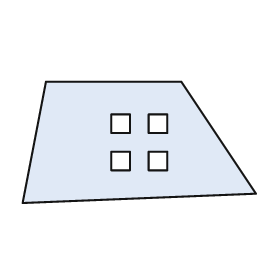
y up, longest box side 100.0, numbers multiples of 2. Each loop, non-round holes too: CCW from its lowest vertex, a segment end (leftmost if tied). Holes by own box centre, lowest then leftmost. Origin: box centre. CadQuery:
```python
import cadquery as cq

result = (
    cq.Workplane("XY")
    .moveTo(-50.0, -26.0)
    .lineTo(50.0, -22.0)
    .lineTo(18.0, 26.0)
    .lineTo(-40.0, 26.0)
    .close()
    .moveTo(-12.0, -12.0)
    .lineTo(-4.0, -12.0)
    .lineTo(-4.0, -4.0)
    .lineTo(-12.0, -4.0)
    .close()
    .moveTo(4.0, -12.0)
    .lineTo(12.0, -12.0)
    .lineTo(12.0, -4.0)
    .lineTo(4.0, -4.0)
    .close()
    .moveTo(-12.0, 4.0)
    .lineTo(-4.0, 4.0)
    .lineTo(-4.0, 12.0)
    .lineTo(-12.0, 12.0)
    .close()
    .moveTo(4.0, 4.0)
    .lineTo(12.0, 4.0)
    .lineTo(12.0, 12.0)
    .lineTo(4.0, 12.0)
    .close()
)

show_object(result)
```